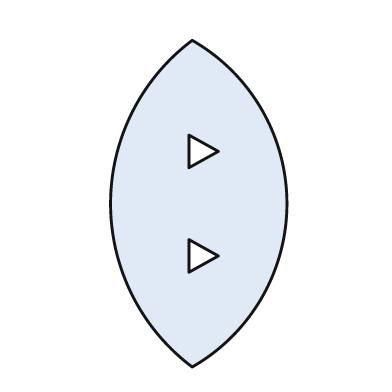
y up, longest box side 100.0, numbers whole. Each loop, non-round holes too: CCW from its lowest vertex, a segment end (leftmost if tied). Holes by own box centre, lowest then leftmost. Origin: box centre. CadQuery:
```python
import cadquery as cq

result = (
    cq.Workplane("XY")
    .moveTo(-2.0, -50.0)
    .threePointArc((27.0, 0.0), (-2.0, 50.0))
    .threePointArc((-27.0, 0.0), (-2.0, -50.0))
    .close()
    .moveTo(-3.0, -21.0)
    .lineTo(6.0, -16.0)
    .lineTo(-3.0, -11.0)
    .close()
    .moveTo(-3.0, 11.0)
    .lineTo(6.0, 16.0)
    .lineTo(-3.0, 21.0)
    .close()
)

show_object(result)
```